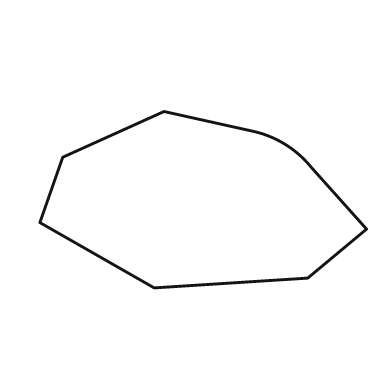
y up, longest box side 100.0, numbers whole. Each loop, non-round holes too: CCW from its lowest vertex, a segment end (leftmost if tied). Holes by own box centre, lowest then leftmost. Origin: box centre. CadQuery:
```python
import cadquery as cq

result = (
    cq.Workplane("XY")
    .moveTo(-15.0, -27.0)
    .lineTo(32.0, -24.0)
    .lineTo(50.0, -9.0)
    .lineTo(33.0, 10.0)
    .threePointArc((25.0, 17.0), (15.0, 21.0))
    .lineTo(-12.0, 27.0)
    .lineTo(-43.0, 13.0)
    .lineTo(-50.0, -7.0)
    .close()
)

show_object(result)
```